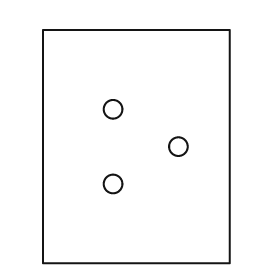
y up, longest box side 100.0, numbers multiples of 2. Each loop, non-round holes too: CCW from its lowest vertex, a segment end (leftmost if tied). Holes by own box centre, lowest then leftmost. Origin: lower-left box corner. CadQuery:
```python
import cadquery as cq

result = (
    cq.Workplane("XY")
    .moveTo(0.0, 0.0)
    .lineTo(80.0, 0.0)
    .lineTo(80.0, 100.0)
    .lineTo(0.0, 100.0)
    .close()
    .moveTo(30.0, 34.0)
    .circle(4.0)
    .moveTo(58.0, 50.0)
    .circle(4.0)
    .moveTo(30.0, 66.0)
    .circle(4.0)
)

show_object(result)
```